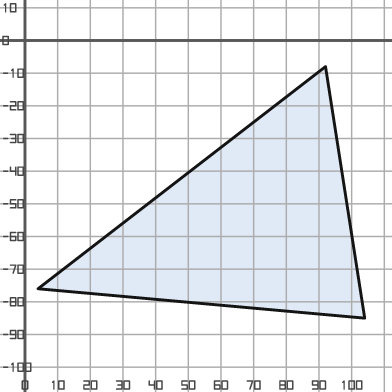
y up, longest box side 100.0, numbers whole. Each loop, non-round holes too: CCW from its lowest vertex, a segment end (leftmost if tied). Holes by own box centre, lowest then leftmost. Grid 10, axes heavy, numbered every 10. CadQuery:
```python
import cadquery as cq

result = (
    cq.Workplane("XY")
    .moveTo(104.0, -85.0)
    .lineTo(92.0, -8.0)
    .lineTo(4.0, -76.0)
    .close()
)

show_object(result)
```